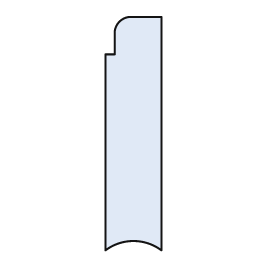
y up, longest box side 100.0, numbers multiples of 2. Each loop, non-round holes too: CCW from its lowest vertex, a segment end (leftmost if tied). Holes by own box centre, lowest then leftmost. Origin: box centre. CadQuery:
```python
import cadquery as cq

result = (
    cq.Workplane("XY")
    .moveTo(-12.0, -50.0)
    .threePointArc((0.0, -46.0), (12.0, -50.0))
    .lineTo(12.0, 50.0)
    .lineTo(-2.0, 50.0)
    .threePointArc((-6.0, 48.0), (-8.0, 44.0))
    .lineTo(-8.0, 34.0)
    .lineTo(-12.0, 34.0)
    .close()
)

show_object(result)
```